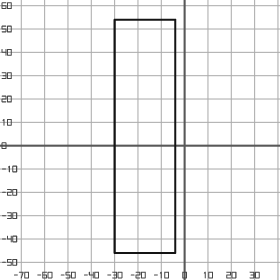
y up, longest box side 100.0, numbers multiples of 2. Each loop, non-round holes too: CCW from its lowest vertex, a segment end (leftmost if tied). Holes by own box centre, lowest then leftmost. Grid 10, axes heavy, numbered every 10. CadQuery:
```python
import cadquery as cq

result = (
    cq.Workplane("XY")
    .moveTo(-30.0, -46.0)
    .lineTo(-4.0, -46.0)
    .lineTo(-4.0, 54.0)
    .lineTo(-30.0, 54.0)
    .close()
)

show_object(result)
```